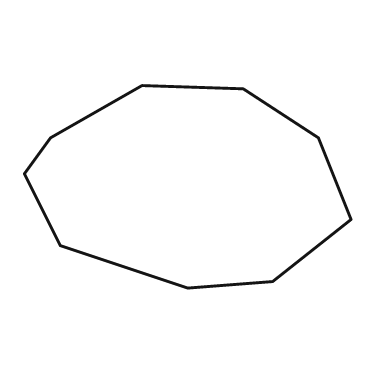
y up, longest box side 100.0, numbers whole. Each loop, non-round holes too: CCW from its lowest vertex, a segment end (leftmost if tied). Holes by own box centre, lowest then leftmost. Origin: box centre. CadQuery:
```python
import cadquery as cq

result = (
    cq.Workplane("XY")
    .moveTo(0.0, -31.0)
    .lineTo(26.0, -29.0)
    .lineTo(50.0, -10.0)
    .lineTo(40.0, 15.0)
    .lineTo(17.0, 30.0)
    .lineTo(-14.0, 31.0)
    .lineTo(-42.0, 15.0)
    .lineTo(-50.0, 4.0)
    .lineTo(-39.0, -18.0)
    .close()
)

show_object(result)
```